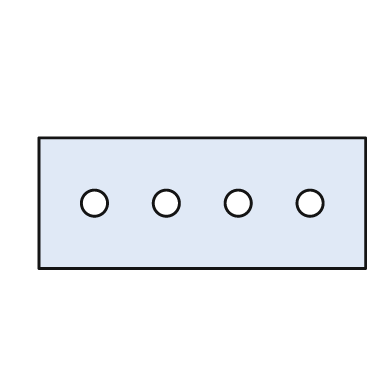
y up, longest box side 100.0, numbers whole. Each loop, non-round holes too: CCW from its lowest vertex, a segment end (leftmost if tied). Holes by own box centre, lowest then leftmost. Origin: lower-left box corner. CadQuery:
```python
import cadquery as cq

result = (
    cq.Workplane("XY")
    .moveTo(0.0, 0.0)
    .lineTo(100.0, 0.0)
    .lineTo(100.0, 40.0)
    .lineTo(0.0, 40.0)
    .close()
    .moveTo(17.0, 20.0)
    .circle(4.0)
    .moveTo(39.0, 20.0)
    .circle(4.0)
    .moveTo(61.0, 20.0)
    .circle(4.0)
    .moveTo(83.0, 20.0)
    .circle(4.0)
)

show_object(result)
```